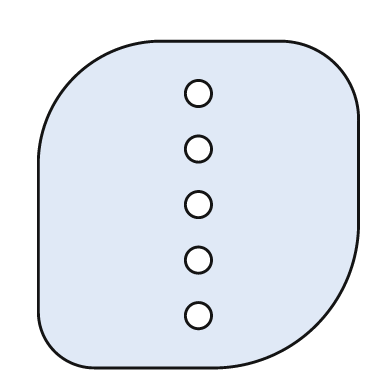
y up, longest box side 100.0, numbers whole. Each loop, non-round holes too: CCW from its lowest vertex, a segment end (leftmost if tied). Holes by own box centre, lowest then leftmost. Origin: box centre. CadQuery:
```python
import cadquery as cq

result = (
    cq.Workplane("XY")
    .moveTo(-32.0, -50.0)
    .lineTo(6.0, -50.0)
    .threePointArc((36.0, -37.0), (49.0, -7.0))
    .lineTo(49.0, 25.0)
    .threePointArc((42.0, 43.0), (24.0, 50.0))
    .lineTo(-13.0, 50.0)
    .threePointArc((-38.0, 39.0), (-49.0, 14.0))
    .lineTo(-49.0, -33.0)
    .threePointArc((-44.0, -45.0), (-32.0, -50.0))
    .close()
    .moveTo(0.0, -34.0)
    .circle(4.0)
    .moveTo(0.0, -17.0)
    .circle(4.0)
    .moveTo(0.0, 0.0)
    .circle(4.0)
    .moveTo(0.0, 17.0)
    .circle(4.0)
    .moveTo(0.0, 34.0)
    .circle(4.0)
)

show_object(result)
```